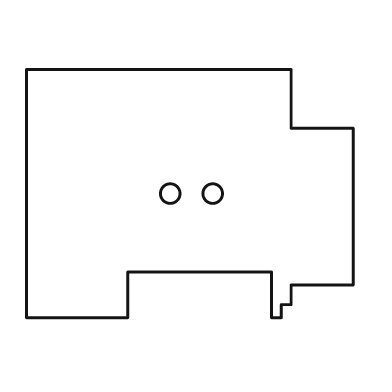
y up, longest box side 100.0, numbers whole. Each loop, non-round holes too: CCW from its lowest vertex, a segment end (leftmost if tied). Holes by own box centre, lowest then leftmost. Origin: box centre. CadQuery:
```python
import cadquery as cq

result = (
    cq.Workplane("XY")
    .moveTo(-50.0, -38.0)
    .lineTo(-19.0, -38.0)
    .lineTo(-19.0, -24.0)
    .lineTo(25.0, -24.0)
    .lineTo(25.0, -38.0)
    .lineTo(28.0, -38.0)
    .lineTo(28.0, -34.0)
    .lineTo(31.0, -34.0)
    .lineTo(31.0, -28.0)
    .lineTo(50.0, -28.0)
    .lineTo(50.0, 20.0)
    .lineTo(31.0, 20.0)
    .lineTo(31.0, 38.0)
    .lineTo(-50.0, 38.0)
    .close()
    .moveTo(-6.0, 0.0)
    .circle(3.0)
    .moveTo(7.0, 0.0)
    .circle(3.0)
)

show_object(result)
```